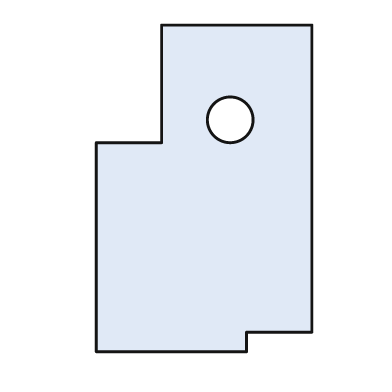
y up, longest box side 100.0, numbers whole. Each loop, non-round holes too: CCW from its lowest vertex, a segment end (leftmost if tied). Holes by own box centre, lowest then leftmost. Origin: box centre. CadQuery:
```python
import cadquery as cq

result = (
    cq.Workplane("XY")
    .moveTo(-33.0, -50.0)
    .lineTo(13.0, -50.0)
    .lineTo(13.0, -44.0)
    .lineTo(33.0, -44.0)
    .lineTo(33.0, 50.0)
    .lineTo(-13.0, 50.0)
    .lineTo(-13.0, 14.0)
    .lineTo(-33.0, 14.0)
    .close()
    .moveTo(8.0, 21.0)
    .circle(7.0)
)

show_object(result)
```